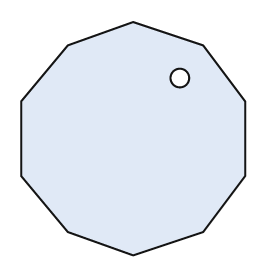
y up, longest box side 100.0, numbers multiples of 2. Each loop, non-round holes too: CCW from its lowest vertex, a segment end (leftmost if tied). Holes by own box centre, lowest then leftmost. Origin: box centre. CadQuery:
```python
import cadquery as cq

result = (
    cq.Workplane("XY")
    .moveTo(0.0, -50.0)
    .lineTo(30.0, -40.0)
    .lineTo(48.0, -16.0)
    .lineTo(48.0, 16.0)
    .lineTo(30.0, 40.0)
    .lineTo(0.0, 50.0)
    .lineTo(-28.0, 40.0)
    .lineTo(-48.0, 16.0)
    .lineTo(-48.0, -16.0)
    .lineTo(-28.0, -40.0)
    .close()
    .moveTo(20.0, 26.0)
    .circle(4.0)
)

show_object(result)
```